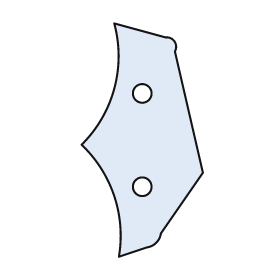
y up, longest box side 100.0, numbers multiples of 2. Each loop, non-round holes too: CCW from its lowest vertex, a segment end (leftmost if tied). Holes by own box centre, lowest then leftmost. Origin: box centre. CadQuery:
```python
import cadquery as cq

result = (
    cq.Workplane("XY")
    .moveTo(-10.0, -50.0)
    .lineTo(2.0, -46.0)
    .threePointArc((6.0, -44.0), (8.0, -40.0))
    .lineTo(26.0, -14.0)
    .lineTo(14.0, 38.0)
    .threePointArc((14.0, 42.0), (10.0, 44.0))
    .lineTo(-12.0, 50.0)
    .threePointArc((-12.0, 22.0), (-26.0, -2.0))
    .threePointArc((-12.0, -24.0), (-10.0, -50.0))
    .close()
    .moveTo(0.0, -20.0)
    .circle(4.0)
    .moveTo(0.0, 20.0)
    .circle(4.0)
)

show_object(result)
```